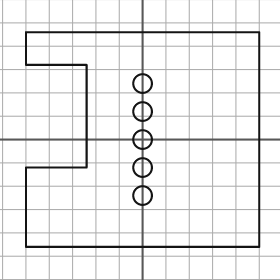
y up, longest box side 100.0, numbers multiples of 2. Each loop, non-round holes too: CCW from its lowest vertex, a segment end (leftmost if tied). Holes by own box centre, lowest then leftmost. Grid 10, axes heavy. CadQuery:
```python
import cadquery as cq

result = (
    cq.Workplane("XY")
    .moveTo(-50.0, -46.0)
    .lineTo(50.0, -46.0)
    .lineTo(50.0, 46.0)
    .lineTo(-50.0, 46.0)
    .lineTo(-50.0, 32.0)
    .lineTo(-24.0, 32.0)
    .lineTo(-24.0, -12.0)
    .lineTo(-50.0, -12.0)
    .close()
    .moveTo(0.0, -24.0)
    .circle(4.0)
    .moveTo(0.0, -12.0)
    .circle(4.0)
    .moveTo(0.0, 0.0)
    .circle(4.0)
    .moveTo(0.0, 12.0)
    .circle(4.0)
    .moveTo(0.0, 24.0)
    .circle(4.0)
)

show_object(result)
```